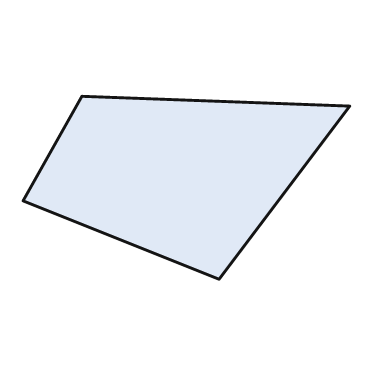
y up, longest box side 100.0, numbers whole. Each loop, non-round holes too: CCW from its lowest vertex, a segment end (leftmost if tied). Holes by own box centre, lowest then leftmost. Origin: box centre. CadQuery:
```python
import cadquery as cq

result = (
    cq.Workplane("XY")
    .moveTo(10.0, -28.0)
    .lineTo(50.0, 25.0)
    .lineTo(-32.0, 28.0)
    .lineTo(-50.0, -4.0)
    .close()
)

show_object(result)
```